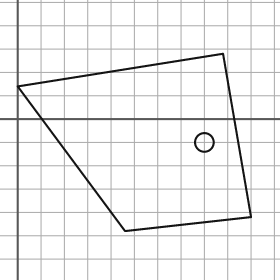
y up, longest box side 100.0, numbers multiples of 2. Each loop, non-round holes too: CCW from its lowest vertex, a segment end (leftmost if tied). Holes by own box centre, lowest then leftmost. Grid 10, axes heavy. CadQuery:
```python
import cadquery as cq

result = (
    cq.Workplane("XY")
    .moveTo(46.0, -48.0)
    .lineTo(100.0, -42.0)
    .lineTo(88.0, 28.0)
    .lineTo(0.0, 14.0)
    .close()
    .moveTo(80.0, -10.0)
    .circle(4.0)
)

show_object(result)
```